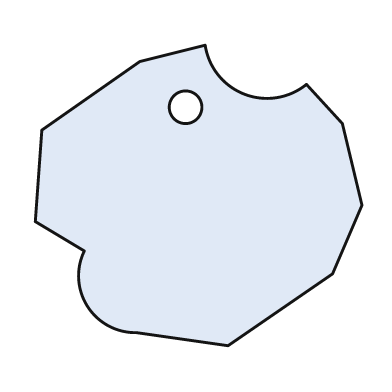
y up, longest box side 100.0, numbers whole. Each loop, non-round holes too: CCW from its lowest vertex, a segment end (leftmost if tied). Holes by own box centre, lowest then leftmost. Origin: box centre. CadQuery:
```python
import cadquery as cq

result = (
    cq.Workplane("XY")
    .moveTo(9.0, -46.0)
    .lineTo(41.0, -24.0)
    .lineTo(50.0, -3.0)
    .lineTo(44.0, 22.0)
    .lineTo(33.0, 34.0)
    .threePointArc((14.0, 31.0), (2.0, 46.0))
    .lineTo(-18.0, 41.0)
    .lineTo(-48.0, 20.0)
    .lineTo(-50.0, -8.0)
    .lineTo(-35.0, -17.0)
    .threePointArc((-34.0, -34.0), (-19.0, -42.0))
    .close()
    .moveTo(-4.0, 27.0)
    .circle(5.0)
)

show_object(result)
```